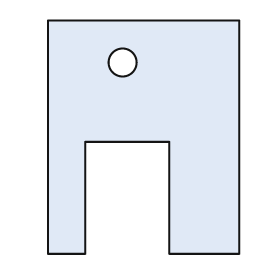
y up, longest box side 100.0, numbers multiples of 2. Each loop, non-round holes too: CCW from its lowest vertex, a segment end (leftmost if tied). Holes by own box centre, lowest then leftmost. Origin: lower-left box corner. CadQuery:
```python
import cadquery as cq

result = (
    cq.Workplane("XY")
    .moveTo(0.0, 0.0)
    .lineTo(16.0, 0.0)
    .lineTo(16.0, 48.0)
    .lineTo(52.0, 48.0)
    .lineTo(52.0, 0.0)
    .lineTo(82.0, 0.0)
    .lineTo(82.0, 100.0)
    .lineTo(0.0, 100.0)
    .close()
    .moveTo(32.0, 82.0)
    .circle(6.0)
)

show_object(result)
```